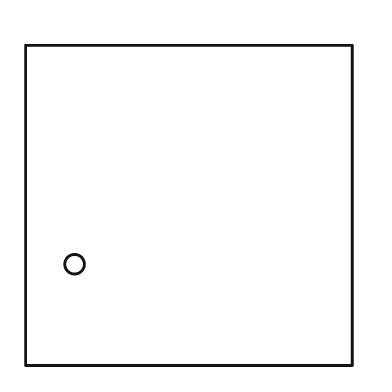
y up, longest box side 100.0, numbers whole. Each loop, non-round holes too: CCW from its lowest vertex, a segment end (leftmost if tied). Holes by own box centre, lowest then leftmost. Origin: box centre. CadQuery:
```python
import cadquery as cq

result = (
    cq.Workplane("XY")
    .moveTo(-50.0, -49.0)
    .lineTo(50.0, -49.0)
    .lineTo(50.0, 49.0)
    .lineTo(-50.0, 49.0)
    .close()
    .moveTo(-35.0, -18.0)
    .circle(3.0)
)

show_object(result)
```